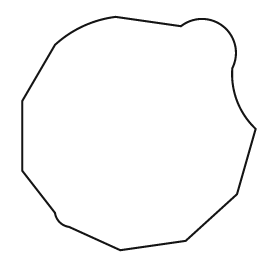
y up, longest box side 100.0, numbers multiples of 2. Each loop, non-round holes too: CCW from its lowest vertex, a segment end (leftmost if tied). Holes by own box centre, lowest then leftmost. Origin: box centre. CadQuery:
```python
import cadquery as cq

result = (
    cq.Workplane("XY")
    .moveTo(-8.0, -50.0)
    .lineTo(20.0, -46.0)
    .lineTo(42.0, -26.0)
    .lineTo(50.0, 2.0)
    .threePointArc((42.0, 14.0), (40.0, 28.0))
    .threePointArc((36.0, 46.0), (18.0, 46.0))
    .lineTo(-10.0, 50.0)
    .threePointArc((-24.0, 46.0), (-36.0, 38.0))
    .lineTo(-50.0, 14.0)
    .lineTo(-50.0, -16.0)
    .lineTo(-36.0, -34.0)
    .threePointArc((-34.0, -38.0), (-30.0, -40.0))
    .close()
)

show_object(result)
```